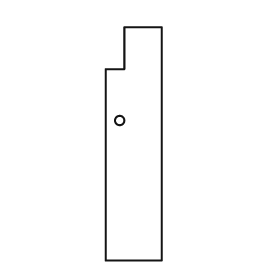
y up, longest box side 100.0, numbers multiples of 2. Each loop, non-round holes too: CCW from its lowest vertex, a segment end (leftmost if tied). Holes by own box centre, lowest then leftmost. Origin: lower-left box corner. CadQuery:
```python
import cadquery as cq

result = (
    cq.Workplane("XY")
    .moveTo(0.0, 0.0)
    .lineTo(24.0, 0.0)
    .lineTo(24.0, 100.0)
    .lineTo(8.0, 100.0)
    .lineTo(8.0, 82.0)
    .lineTo(0.0, 82.0)
    .close()
    .moveTo(6.0, 60.0)
    .circle(2.0)
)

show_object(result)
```